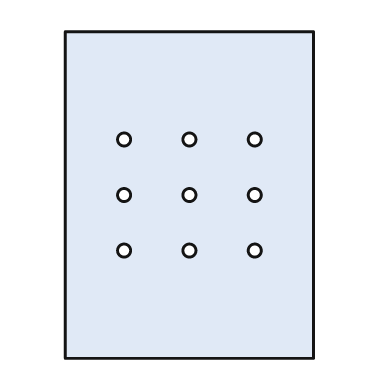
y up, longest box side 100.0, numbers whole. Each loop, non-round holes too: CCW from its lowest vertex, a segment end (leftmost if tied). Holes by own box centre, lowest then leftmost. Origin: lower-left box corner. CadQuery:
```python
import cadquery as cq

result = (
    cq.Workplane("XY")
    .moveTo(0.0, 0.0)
    .lineTo(76.0, 0.0)
    .lineTo(76.0, 100.0)
    .lineTo(0.0, 100.0)
    .close()
    .moveTo(18.0, 33.0)
    .circle(2.0)
    .moveTo(38.0, 33.0)
    .circle(2.0)
    .moveTo(58.0, 33.0)
    .circle(2.0)
    .moveTo(18.0, 50.0)
    .circle(2.0)
    .moveTo(38.0, 50.0)
    .circle(2.0)
    .moveTo(58.0, 50.0)
    .circle(2.0)
    .moveTo(18.0, 67.0)
    .circle(2.0)
    .moveTo(38.0, 67.0)
    .circle(2.0)
    .moveTo(58.0, 67.0)
    .circle(2.0)
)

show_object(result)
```